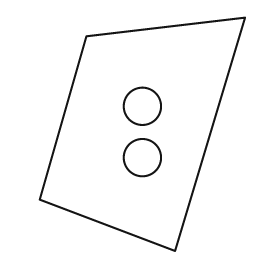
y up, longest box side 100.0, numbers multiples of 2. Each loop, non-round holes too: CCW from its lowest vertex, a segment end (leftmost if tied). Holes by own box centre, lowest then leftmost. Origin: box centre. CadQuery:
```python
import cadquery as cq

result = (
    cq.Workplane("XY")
    .moveTo(14.0, -50.0)
    .lineTo(44.0, 50.0)
    .lineTo(-24.0, 42.0)
    .lineTo(-44.0, -28.0)
    .close()
    .moveTo(0.0, -10.0)
    .circle(8.0)
    .moveTo(0.0, 12.0)
    .circle(8.0)
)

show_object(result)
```